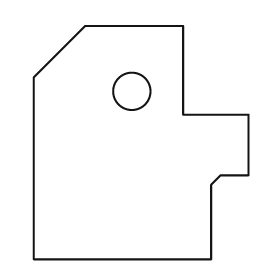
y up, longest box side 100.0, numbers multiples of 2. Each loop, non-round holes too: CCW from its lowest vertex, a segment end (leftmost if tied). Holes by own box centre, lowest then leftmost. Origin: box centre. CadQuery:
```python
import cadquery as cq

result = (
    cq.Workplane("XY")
    .moveTo(-46.0, -50.0)
    .lineTo(30.0, -50.0)
    .lineTo(30.0, -18.0)
    .lineTo(34.0, -14.0)
    .lineTo(46.0, -14.0)
    .lineTo(46.0, 12.0)
    .lineTo(18.0, 12.0)
    .lineTo(18.0, 50.0)
    .lineTo(-24.0, 50.0)
    .lineTo(-46.0, 28.0)
    .close()
    .moveTo(-4.0, 22.0)
    .circle(8.0)
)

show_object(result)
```